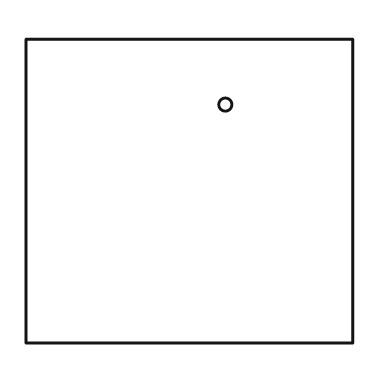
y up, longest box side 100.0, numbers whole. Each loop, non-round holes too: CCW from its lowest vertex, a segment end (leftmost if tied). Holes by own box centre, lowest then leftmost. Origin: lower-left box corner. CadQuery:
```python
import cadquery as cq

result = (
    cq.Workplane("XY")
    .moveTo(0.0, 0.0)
    .lineTo(100.0, 0.0)
    .lineTo(100.0, 93.0)
    .lineTo(0.0, 93.0)
    .close()
    .moveTo(61.0, 73.0)
    .circle(2.0)
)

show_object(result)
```